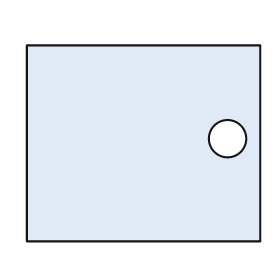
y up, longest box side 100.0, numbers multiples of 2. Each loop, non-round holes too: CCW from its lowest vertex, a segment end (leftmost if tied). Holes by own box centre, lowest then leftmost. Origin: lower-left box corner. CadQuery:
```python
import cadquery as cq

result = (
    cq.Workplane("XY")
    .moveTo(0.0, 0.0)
    .lineTo(100.0, 0.0)
    .lineTo(100.0, 84.0)
    .lineTo(0.0, 84.0)
    .close()
    .moveTo(86.0, 44.0)
    .circle(8.0)
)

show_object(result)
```